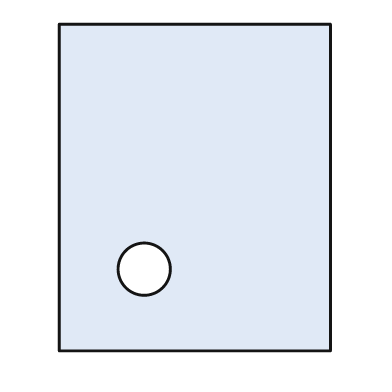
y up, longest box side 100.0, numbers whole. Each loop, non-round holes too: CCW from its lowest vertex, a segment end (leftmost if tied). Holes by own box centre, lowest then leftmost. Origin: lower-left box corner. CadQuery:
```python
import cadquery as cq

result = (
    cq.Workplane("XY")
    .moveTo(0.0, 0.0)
    .lineTo(83.0, 0.0)
    .lineTo(83.0, 100.0)
    .lineTo(0.0, 100.0)
    .close()
    .moveTo(26.0, 25.0)
    .circle(8.0)
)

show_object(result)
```